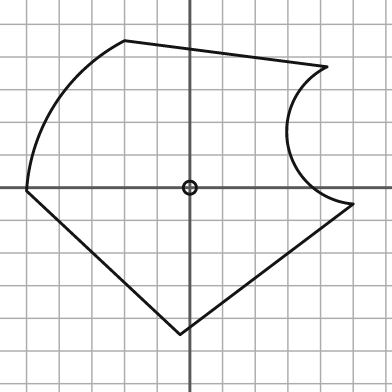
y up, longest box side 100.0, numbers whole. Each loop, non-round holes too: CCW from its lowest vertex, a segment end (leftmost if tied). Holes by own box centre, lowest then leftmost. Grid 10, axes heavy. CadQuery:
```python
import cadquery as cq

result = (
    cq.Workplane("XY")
    .moveTo(-3.0, -45.0)
    .lineTo(50.0, -5.0)
    .threePointArc((30.0, 13.0), (42.0, 37.0))
    .lineTo(-20.0, 45.0)
    .threePointArc((-41.0, 26.0), (-50.0, -1.0))
    .close()
    .moveTo(0.0, 0.0)
    .circle(2.0)
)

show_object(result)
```